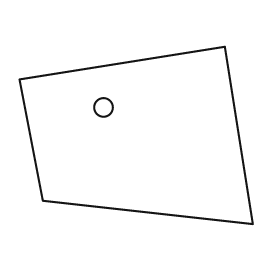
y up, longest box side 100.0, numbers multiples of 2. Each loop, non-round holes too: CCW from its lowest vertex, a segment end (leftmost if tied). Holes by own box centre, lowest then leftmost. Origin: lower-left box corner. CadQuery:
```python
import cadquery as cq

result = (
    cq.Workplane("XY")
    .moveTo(100.0, 0.0)
    .lineTo(88.0, 76.0)
    .lineTo(0.0, 62.0)
    .lineTo(10.0, 10.0)
    .close()
    .moveTo(36.0, 50.0)
    .circle(4.0)
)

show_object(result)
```